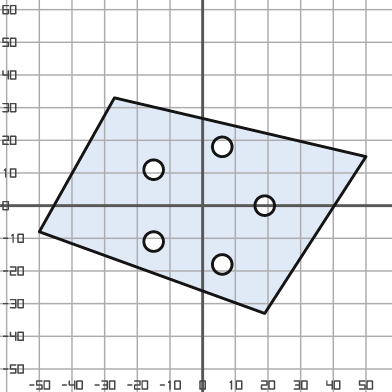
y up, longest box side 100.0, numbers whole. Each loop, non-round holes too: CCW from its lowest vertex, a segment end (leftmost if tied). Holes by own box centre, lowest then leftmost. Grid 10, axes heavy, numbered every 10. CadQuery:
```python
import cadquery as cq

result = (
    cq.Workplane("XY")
    .moveTo(19.0, -33.0)
    .lineTo(50.0, 15.0)
    .lineTo(-27.0, 33.0)
    .lineTo(-50.0, -8.0)
    .close()
    .moveTo(6.0, -18.0)
    .circle(3.0)
    .moveTo(-15.0, -11.0)
    .circle(3.0)
    .moveTo(19.0, 0.0)
    .circle(3.0)
    .moveTo(-15.0, 11.0)
    .circle(3.0)
    .moveTo(6.0, 18.0)
    .circle(3.0)
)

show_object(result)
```